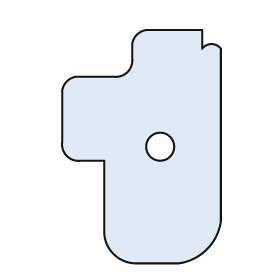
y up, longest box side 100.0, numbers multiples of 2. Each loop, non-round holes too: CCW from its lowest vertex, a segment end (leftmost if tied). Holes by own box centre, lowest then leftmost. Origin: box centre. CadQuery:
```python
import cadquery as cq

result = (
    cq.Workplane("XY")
    .moveTo(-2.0, -50.0)
    .lineTo(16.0, -50.0)
    .threePointArc((28.0, -44.0), (34.0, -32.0))
    .lineTo(34.0, 42.0)
    .threePointArc((30.0, 44.0), (26.0, 42.0))
    .lineTo(26.0, 50.0)
    .lineTo(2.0, 50.0)
    .threePointArc((-2.0, 48.0), (-4.0, 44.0))
    .lineTo(-4.0, 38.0)
    .threePointArc((-6.0, 32.0), (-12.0, 30.0))
    .lineTo(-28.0, 30.0)
    .threePointArc((-32.0, 28.0), (-34.0, 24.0))
    .lineTo(-34.0, 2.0)
    .threePointArc((-32.0, -4.0), (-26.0, -6.0))
    .lineTo(-16.0, -6.0)
    .lineTo(-16.0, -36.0)
    .threePointArc((-12.0, -46.0), (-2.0, -50.0))
    .close()
    .moveTo(8.0, 0.0)
    .circle(6.0)
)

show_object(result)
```